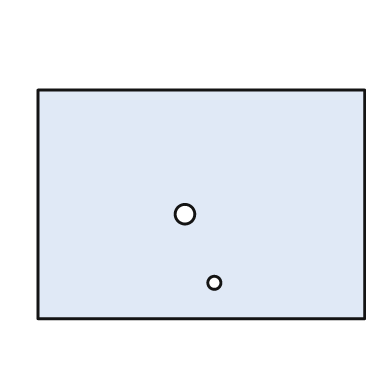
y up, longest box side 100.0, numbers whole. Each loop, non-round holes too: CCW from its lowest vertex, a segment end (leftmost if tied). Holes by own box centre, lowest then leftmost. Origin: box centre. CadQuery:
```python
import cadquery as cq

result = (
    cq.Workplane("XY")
    .moveTo(-50.0, -35.0)
    .lineTo(50.0, -35.0)
    .lineTo(50.0, 35.0)
    .lineTo(-50.0, 35.0)
    .close()
    .moveTo(4.0, -24.0)
    .circle(2.0)
    .moveTo(-5.0, -3.0)
    .circle(3.0)
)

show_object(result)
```